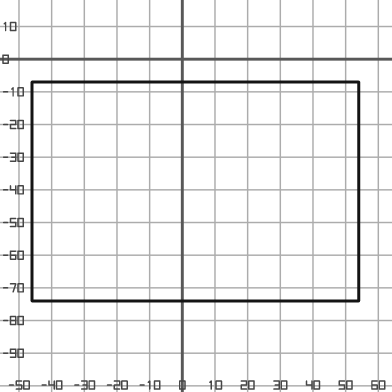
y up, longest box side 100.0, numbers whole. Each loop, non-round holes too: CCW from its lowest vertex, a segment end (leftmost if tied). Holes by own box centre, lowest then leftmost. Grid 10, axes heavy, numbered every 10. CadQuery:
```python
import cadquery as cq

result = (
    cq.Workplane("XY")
    .moveTo(-46.0, -74.0)
    .lineTo(54.0, -74.0)
    .lineTo(54.0, -7.0)
    .lineTo(-46.0, -7.0)
    .close()
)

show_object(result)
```